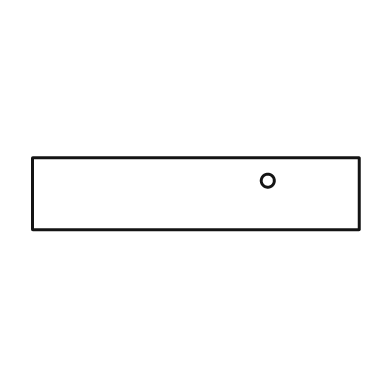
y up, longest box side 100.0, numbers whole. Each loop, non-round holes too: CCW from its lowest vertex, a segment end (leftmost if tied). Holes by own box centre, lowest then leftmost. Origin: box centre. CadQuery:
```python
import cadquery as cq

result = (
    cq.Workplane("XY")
    .moveTo(-50.0, -11.0)
    .lineTo(50.0, -11.0)
    .lineTo(50.0, 11.0)
    .lineTo(-50.0, 11.0)
    .close()
    .moveTo(22.0, 4.0)
    .circle(2.0)
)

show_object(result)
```